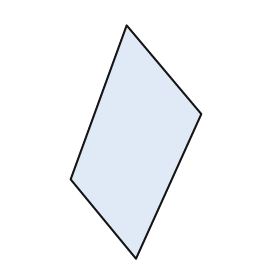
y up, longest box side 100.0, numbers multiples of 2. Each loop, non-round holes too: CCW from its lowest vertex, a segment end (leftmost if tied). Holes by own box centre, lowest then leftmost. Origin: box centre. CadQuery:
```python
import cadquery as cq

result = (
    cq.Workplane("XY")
    .moveTo(0.0, -50.0)
    .lineTo(28.0, 12.0)
    .lineTo(-4.0, 50.0)
    .lineTo(-28.0, -16.0)
    .close()
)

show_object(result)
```